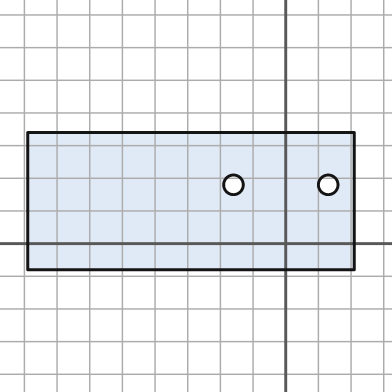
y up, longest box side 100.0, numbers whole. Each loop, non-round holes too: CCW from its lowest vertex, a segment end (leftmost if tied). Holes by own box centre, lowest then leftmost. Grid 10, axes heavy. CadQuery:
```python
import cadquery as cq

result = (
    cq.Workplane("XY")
    .moveTo(-79.0, -8.0)
    .lineTo(21.0, -8.0)
    .lineTo(21.0, 34.0)
    .lineTo(-79.0, 34.0)
    .close()
    .moveTo(-16.0, 18.0)
    .circle(3.0)
    .moveTo(13.0, 18.0)
    .circle(3.0)
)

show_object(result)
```